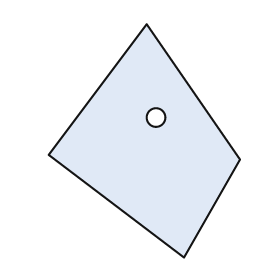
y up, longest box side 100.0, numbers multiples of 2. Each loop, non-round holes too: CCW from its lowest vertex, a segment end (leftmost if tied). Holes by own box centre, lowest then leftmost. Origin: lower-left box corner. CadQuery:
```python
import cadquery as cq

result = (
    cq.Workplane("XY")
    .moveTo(58.0, 0.0)
    .lineTo(82.0, 42.0)
    .lineTo(42.0, 100.0)
    .lineTo(0.0, 44.0)
    .close()
    .moveTo(46.0, 60.0)
    .circle(4.0)
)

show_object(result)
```